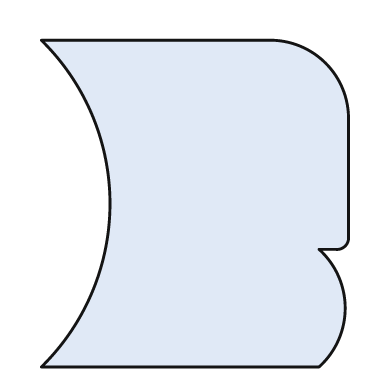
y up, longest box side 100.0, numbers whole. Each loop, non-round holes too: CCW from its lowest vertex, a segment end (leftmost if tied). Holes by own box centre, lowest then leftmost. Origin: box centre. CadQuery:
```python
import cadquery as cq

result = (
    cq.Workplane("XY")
    .moveTo(-47.0, -50.0)
    .lineTo(38.0, -50.0)
    .threePointArc((46.0, -32.0), (38.0, -14.0))
    .lineTo(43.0, -14.0)
    .threePointArc((46.0, -13.0), (47.0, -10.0))
    .lineTo(47.0, 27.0)
    .threePointArc((40.0, 43.0), (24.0, 50.0))
    .lineTo(-47.0, 50.0)
    .threePointArc((-26.0, 0.0), (-47.0, -50.0))
    .close()
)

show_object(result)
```